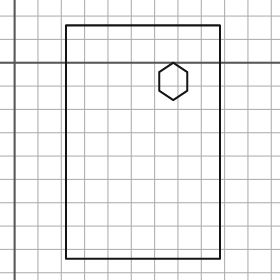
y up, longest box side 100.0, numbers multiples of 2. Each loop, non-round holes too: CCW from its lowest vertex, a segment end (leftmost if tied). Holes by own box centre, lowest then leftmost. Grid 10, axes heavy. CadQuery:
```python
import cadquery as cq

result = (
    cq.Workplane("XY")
    .moveTo(22.0, -84.0)
    .lineTo(88.0, -84.0)
    .lineTo(88.0, 16.0)
    .lineTo(22.0, 16.0)
    .close()
    .moveTo(68.0, -16.0)
    .lineTo(74.0, -12.0)
    .lineTo(74.0, -4.0)
    .lineTo(68.0, 0.0)
    .lineTo(62.0, -4.0)
    .lineTo(62.0, -12.0)
    .close()
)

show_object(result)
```